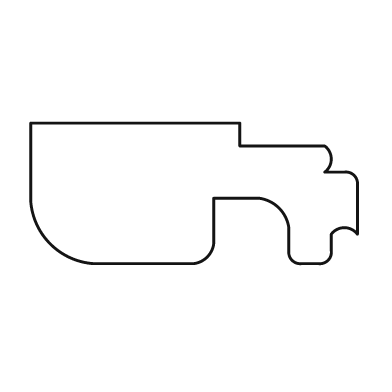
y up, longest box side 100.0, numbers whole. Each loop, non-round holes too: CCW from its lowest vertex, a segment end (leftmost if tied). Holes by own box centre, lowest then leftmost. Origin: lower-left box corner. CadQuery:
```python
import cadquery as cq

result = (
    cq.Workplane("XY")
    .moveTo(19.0, 0.0)
    .lineTo(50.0, 0.0)
    .threePointArc((54.0, 2.0), (56.0, 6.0))
    .lineTo(56.0, 20.0)
    .lineTo(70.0, 20.0)
    .threePointArc((76.0, 17.0), (79.0, 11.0))
    .lineTo(79.0, 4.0)
    .threePointArc((80.0, 1.0), (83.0, 0.0))
    .lineTo(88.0, 0.0)
    .threePointArc((91.0, 1.0), (92.0, 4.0))
    .lineTo(92.0, 9.0)
    .threePointArc((96.0, 11.0), (100.0, 9.0))
    .lineTo(100.0, 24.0)
    .threePointArc((99.0, 27.0), (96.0, 28.0))
    .lineTo(90.0, 28.0)
    .threePointArc((92.0, 32.0), (90.0, 36.0))
    .lineTo(64.0, 36.0)
    .lineTo(64.0, 43.0)
    .lineTo(0.0, 43.0)
    .lineTo(0.0, 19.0)
    .threePointArc((6.0, 6.0), (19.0, 0.0))
    .close()
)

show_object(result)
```